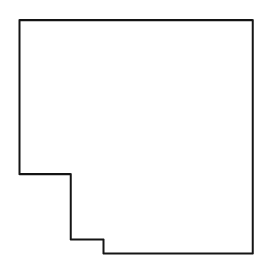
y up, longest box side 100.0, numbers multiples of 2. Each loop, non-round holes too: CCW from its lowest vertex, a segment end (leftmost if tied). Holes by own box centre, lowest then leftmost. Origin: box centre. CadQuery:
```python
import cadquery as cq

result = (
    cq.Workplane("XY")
    .moveTo(-14.0, -50.0)
    .lineTo(50.0, -50.0)
    .lineTo(50.0, 50.0)
    .lineTo(-50.0, 50.0)
    .lineTo(-50.0, -16.0)
    .lineTo(-28.0, -16.0)
    .lineTo(-28.0, -44.0)
    .lineTo(-14.0, -44.0)
    .close()
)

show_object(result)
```